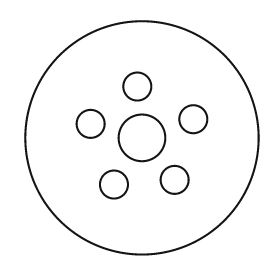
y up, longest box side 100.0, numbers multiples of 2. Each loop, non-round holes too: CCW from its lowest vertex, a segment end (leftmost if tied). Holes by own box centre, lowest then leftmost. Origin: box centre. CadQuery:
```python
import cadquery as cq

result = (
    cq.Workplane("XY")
    .moveTo(0.0, 0.0)
    .circle(50.0)
    .moveTo(-12.0, -20.0)
    .circle(6.0)
    .moveTo(14.0, -18.0)
    .circle(6.0)
    .moveTo(0.0, 0.0)
    .circle(10.0)
    .moveTo(-22.0, 6.0)
    .circle(6.0)
    .moveTo(22.0, 8.0)
    .circle(6.0)
    .moveTo(-2.0, 22.0)
    .circle(6.0)
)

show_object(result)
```